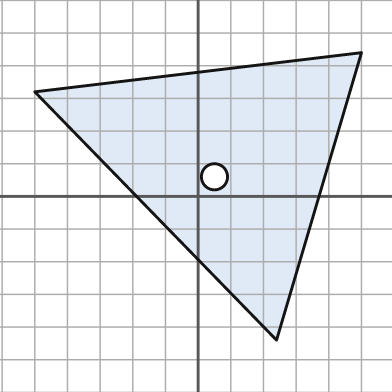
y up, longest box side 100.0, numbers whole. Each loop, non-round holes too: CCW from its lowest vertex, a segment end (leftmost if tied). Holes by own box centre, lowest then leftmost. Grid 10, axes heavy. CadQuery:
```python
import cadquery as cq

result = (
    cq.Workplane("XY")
    .moveTo(24.0, -44.0)
    .lineTo(50.0, 44.0)
    .lineTo(-50.0, 32.0)
    .close()
    .moveTo(5.0, 6.0)
    .circle(4.0)
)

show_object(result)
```